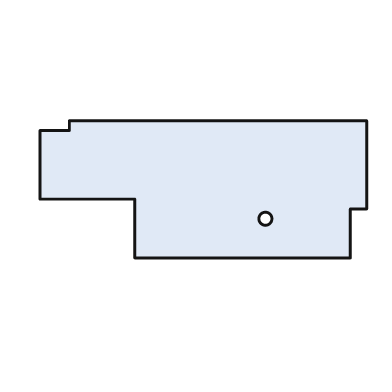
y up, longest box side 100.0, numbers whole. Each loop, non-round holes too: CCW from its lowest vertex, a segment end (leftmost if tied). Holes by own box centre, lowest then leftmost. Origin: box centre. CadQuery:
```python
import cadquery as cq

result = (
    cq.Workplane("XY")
    .moveTo(-21.0, -21.0)
    .lineTo(45.0, -21.0)
    .lineTo(45.0, -6.0)
    .lineTo(50.0, -6.0)
    .lineTo(50.0, 21.0)
    .lineTo(-41.0, 21.0)
    .lineTo(-41.0, 18.0)
    .lineTo(-50.0, 18.0)
    .lineTo(-50.0, -3.0)
    .lineTo(-21.0, -3.0)
    .close()
    .moveTo(19.0, -9.0)
    .circle(2.0)
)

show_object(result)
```